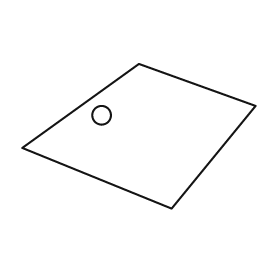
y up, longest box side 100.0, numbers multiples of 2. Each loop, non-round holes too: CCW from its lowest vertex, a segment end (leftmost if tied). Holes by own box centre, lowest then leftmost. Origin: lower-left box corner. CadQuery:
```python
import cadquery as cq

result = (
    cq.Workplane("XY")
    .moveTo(64.0, 0.0)
    .lineTo(100.0, 44.0)
    .lineTo(50.0, 62.0)
    .lineTo(0.0, 26.0)
    .close()
    .moveTo(34.0, 40.0)
    .circle(4.0)
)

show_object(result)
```